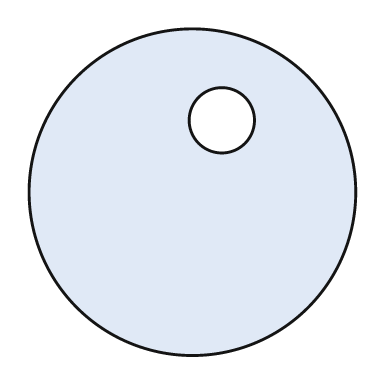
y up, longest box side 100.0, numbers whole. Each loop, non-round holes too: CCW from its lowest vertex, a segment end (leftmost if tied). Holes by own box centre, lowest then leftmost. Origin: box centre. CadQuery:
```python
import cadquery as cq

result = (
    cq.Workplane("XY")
    .moveTo(0.0, 0.0)
    .circle(50.0)
    .moveTo(9.0, 22.0)
    .circle(10.0)
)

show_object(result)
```